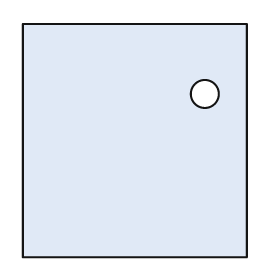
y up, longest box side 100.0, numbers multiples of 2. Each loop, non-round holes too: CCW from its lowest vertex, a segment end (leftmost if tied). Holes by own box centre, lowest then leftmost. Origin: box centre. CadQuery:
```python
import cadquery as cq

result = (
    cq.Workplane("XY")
    .moveTo(-48.0, -50.0)
    .lineTo(48.0, -50.0)
    .lineTo(48.0, 50.0)
    .lineTo(-48.0, 50.0)
    .close()
    .moveTo(30.0, 20.0)
    .circle(6.0)
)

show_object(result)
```